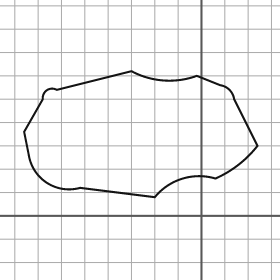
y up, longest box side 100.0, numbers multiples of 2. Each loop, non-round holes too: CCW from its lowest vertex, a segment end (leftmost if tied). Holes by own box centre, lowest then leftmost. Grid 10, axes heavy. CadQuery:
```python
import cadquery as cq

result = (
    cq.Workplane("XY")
    .moveTo(-20.0, 8.0)
    .threePointArc((-8.0, 16.0), (6.0, 16.0))
    .threePointArc((16.0, 22.0), (24.0, 30.0))
    .lineTo(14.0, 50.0)
    .threePointArc((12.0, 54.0), (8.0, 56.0))
    .lineTo(-2.0, 60.0)
    .threePointArc((-16.0, 58.0), (-30.0, 62.0))
    .lineTo(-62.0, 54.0)
    .threePointArc((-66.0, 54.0), (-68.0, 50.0))
    .lineTo(-76.0, 36.0)
    .lineTo(-74.0, 26.0)
    .threePointArc((-66.0, 14.0), (-52.0, 12.0))
    .close()
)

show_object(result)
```